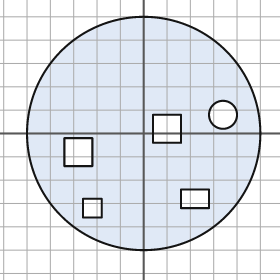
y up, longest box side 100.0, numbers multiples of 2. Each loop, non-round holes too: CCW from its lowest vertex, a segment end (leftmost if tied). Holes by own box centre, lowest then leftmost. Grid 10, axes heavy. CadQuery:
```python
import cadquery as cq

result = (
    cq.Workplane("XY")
    .moveTo(0.0, 0.0)
    .circle(50.0)
    .moveTo(-26.0, -36.0)
    .lineTo(-18.0, -36.0)
    .lineTo(-18.0, -28.0)
    .lineTo(-26.0, -28.0)
    .close()
    .moveTo(16.0, -32.0)
    .lineTo(28.0, -32.0)
    .lineTo(28.0, -24.0)
    .lineTo(16.0, -24.0)
    .close()
    .moveTo(-34.0, -14.0)
    .lineTo(-22.0, -14.0)
    .lineTo(-22.0, -2.0)
    .lineTo(-34.0, -2.0)
    .close()
    .moveTo(4.0, -4.0)
    .lineTo(16.0, -4.0)
    .lineTo(16.0, 8.0)
    .lineTo(4.0, 8.0)
    .close()
    .moveTo(34.0, 8.0)
    .circle(6.0)
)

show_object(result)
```